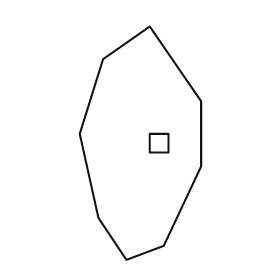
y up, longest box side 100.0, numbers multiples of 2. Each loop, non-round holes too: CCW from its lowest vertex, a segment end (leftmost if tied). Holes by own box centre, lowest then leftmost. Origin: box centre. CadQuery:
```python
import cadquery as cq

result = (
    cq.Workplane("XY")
    .moveTo(-6.0, -50.0)
    .lineTo(10.0, -44.0)
    .lineTo(26.0, -10.0)
    .lineTo(26.0, 18.0)
    .lineTo(4.0, 50.0)
    .lineTo(-16.0, 36.0)
    .lineTo(-26.0, 4.0)
    .lineTo(-18.0, -32.0)
    .close()
    .moveTo(4.0, -4.0)
    .lineTo(12.0, -4.0)
    .lineTo(12.0, 4.0)
    .lineTo(4.0, 4.0)
    .close()
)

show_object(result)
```